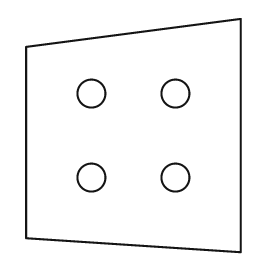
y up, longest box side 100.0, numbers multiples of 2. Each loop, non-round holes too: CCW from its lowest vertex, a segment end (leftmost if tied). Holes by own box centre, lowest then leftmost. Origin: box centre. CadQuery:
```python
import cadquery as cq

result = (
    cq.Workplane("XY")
    .moveTo(46.0, -50.0)
    .lineTo(46.0, 50.0)
    .lineTo(-46.0, 38.0)
    .lineTo(-46.0, -44.0)
    .close()
    .moveTo(-18.0, -18.0)
    .circle(6.0)
    .moveTo(18.0, -18.0)
    .circle(6.0)
    .moveTo(-18.0, 18.0)
    .circle(6.0)
    .moveTo(18.0, 18.0)
    .circle(6.0)
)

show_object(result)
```